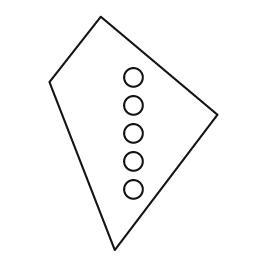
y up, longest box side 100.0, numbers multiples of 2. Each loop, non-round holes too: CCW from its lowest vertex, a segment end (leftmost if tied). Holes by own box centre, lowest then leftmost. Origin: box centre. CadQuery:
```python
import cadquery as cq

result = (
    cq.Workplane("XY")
    .moveTo(-8.0, -50.0)
    .lineTo(36.0, 8.0)
    .lineTo(-14.0, 50.0)
    .lineTo(-36.0, 22.0)
    .close()
    .moveTo(0.0, -24.0)
    .circle(4.0)
    .moveTo(0.0, -12.0)
    .circle(4.0)
    .moveTo(0.0, 0.0)
    .circle(4.0)
    .moveTo(0.0, 12.0)
    .circle(4.0)
    .moveTo(0.0, 24.0)
    .circle(4.0)
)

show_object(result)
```